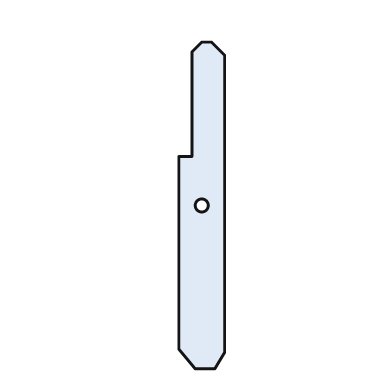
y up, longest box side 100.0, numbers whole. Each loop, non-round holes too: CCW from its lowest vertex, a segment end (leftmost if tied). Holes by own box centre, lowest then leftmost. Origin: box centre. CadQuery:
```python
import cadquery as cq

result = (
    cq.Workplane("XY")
    .moveTo(-2.0, -50.0)
    .lineTo(4.0, -50.0)
    .lineTo(7.0, -45.0)
    .lineTo(7.0, 46.0)
    .lineTo(3.0, 50.0)
    .lineTo(0.0, 50.0)
    .lineTo(-3.0, 47.0)
    .lineTo(-3.0, 15.0)
    .lineTo(-7.0, 15.0)
    .lineTo(-7.0, -44.0)
    .close()
    .moveTo(0.0, 0.0)
    .circle(2.0)
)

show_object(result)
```